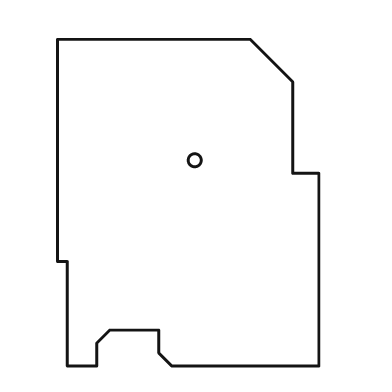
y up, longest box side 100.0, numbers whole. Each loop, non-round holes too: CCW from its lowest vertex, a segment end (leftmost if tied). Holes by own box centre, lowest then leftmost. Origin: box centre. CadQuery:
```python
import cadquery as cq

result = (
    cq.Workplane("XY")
    .moveTo(-37.0, -50.0)
    .lineTo(-28.0, -50.0)
    .lineTo(-28.0, -43.0)
    .lineTo(-24.0, -39.0)
    .lineTo(-9.0, -39.0)
    .lineTo(-9.0, -46.0)
    .lineTo(-5.0, -50.0)
    .lineTo(40.0, -50.0)
    .lineTo(40.0, 9.0)
    .lineTo(32.0, 9.0)
    .lineTo(32.0, 37.0)
    .lineTo(19.0, 50.0)
    .lineTo(-40.0, 50.0)
    .lineTo(-40.0, -18.0)
    .lineTo(-37.0, -18.0)
    .close()
    .moveTo(2.0, 13.0)
    .circle(2.0)
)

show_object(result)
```